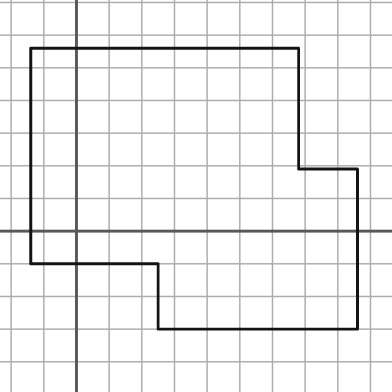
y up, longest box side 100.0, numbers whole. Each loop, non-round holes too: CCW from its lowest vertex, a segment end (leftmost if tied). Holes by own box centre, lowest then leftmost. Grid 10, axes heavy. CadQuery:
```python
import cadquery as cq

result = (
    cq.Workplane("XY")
    .moveTo(25.0, -30.0)
    .lineTo(86.0, -30.0)
    .lineTo(86.0, 19.0)
    .lineTo(68.0, 19.0)
    .lineTo(68.0, 56.0)
    .lineTo(-14.0, 56.0)
    .lineTo(-14.0, -10.0)
    .lineTo(25.0, -10.0)
    .close()
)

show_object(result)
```